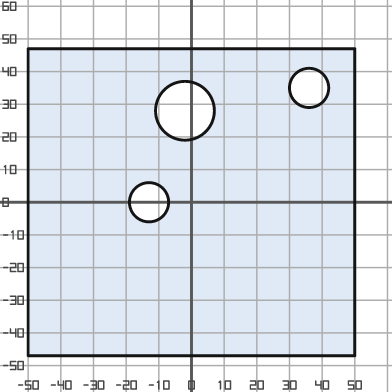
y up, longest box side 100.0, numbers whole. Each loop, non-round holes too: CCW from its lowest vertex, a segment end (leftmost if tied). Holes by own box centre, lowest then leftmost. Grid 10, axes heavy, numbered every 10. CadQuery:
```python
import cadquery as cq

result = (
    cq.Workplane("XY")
    .moveTo(-50.0, -47.0)
    .lineTo(50.0, -47.0)
    .lineTo(50.0, 47.0)
    .lineTo(-50.0, 47.0)
    .close()
    .moveTo(-13.0, 0.0)
    .circle(6.0)
    .moveTo(-2.0, 28.0)
    .circle(9.0)
    .moveTo(36.0, 35.0)
    .circle(6.0)
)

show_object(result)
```